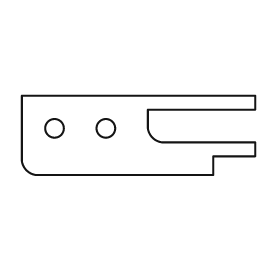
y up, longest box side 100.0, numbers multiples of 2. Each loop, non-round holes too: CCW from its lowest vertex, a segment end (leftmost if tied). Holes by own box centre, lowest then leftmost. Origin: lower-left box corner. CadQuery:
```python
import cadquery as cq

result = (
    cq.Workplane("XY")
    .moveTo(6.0, 0.0)
    .lineTo(82.0, 0.0)
    .lineTo(82.0, 8.0)
    .lineTo(100.0, 8.0)
    .lineTo(100.0, 14.0)
    .lineTo(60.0, 14.0)
    .threePointArc((56.0, 16.0), (54.0, 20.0))
    .lineTo(54.0, 28.0)
    .lineTo(100.0, 28.0)
    .lineTo(100.0, 34.0)
    .lineTo(0.0, 34.0)
    .lineTo(0.0, 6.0)
    .threePointArc((2.0, 2.0), (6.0, 0.0))
    .close()
    .moveTo(14.0, 20.0)
    .circle(4.0)
    .moveTo(36.0, 20.0)
    .circle(4.0)
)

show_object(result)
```